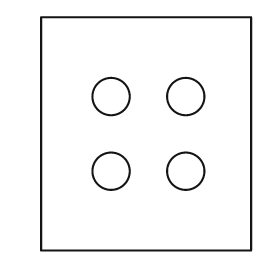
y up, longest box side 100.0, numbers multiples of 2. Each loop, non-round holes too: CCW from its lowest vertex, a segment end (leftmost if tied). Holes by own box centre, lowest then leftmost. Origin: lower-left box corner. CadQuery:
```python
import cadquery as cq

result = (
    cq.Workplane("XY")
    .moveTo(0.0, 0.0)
    .lineTo(90.0, 0.0)
    .lineTo(90.0, 100.0)
    .lineTo(0.0, 100.0)
    .close()
    .moveTo(30.0, 34.0)
    .circle(8.0)
    .moveTo(62.0, 34.0)
    .circle(8.0)
    .moveTo(30.0, 66.0)
    .circle(8.0)
    .moveTo(62.0, 66.0)
    .circle(8.0)
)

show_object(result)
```